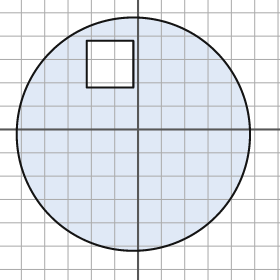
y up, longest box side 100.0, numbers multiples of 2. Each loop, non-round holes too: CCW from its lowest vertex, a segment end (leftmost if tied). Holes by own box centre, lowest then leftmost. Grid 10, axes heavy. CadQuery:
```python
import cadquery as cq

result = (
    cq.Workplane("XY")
    .moveTo(-2.0, -2.0)
    .circle(50.0)
    .moveTo(-22.0, 18.0)
    .lineTo(-2.0, 18.0)
    .lineTo(-2.0, 38.0)
    .lineTo(-22.0, 38.0)
    .close()
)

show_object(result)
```